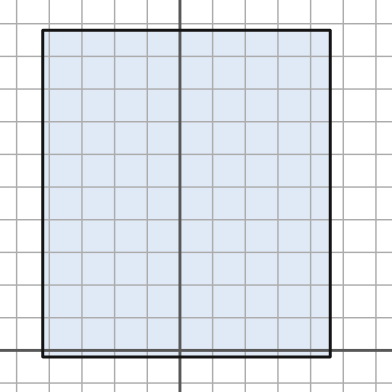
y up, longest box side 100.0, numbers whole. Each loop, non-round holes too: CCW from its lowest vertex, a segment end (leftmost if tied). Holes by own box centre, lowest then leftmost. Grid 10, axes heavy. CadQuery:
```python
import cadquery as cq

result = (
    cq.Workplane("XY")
    .moveTo(-42.0, -2.0)
    .lineTo(46.0, -2.0)
    .lineTo(46.0, 98.0)
    .lineTo(-42.0, 98.0)
    .close()
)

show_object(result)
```